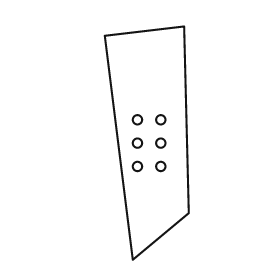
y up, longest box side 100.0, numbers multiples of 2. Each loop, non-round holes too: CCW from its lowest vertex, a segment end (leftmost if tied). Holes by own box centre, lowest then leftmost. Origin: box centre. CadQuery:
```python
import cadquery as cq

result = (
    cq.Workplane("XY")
    .moveTo(-6.0, -50.0)
    .lineTo(18.0, -30.0)
    .lineTo(16.0, 50.0)
    .lineTo(-18.0, 46.0)
    .close()
    .moveTo(-4.0, -10.0)
    .circle(2.0)
    .moveTo(6.0, -10.0)
    .circle(2.0)
    .moveTo(-4.0, 0.0)
    .circle(2.0)
    .moveTo(6.0, 0.0)
    .circle(2.0)
    .moveTo(-4.0, 10.0)
    .circle(2.0)
    .moveTo(6.0, 10.0)
    .circle(2.0)
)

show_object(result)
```